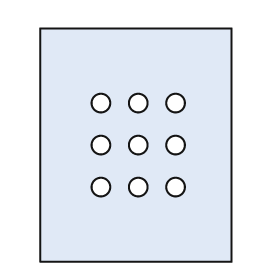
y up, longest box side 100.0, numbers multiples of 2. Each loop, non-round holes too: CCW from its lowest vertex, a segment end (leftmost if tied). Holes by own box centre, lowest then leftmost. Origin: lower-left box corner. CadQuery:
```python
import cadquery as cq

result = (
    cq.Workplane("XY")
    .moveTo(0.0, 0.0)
    .lineTo(82.0, 0.0)
    .lineTo(82.0, 100.0)
    .lineTo(0.0, 100.0)
    .close()
    .moveTo(26.0, 32.0)
    .circle(4.0)
    .moveTo(42.0, 32.0)
    .circle(4.0)
    .moveTo(58.0, 32.0)
    .circle(4.0)
    .moveTo(26.0, 50.0)
    .circle(4.0)
    .moveTo(42.0, 50.0)
    .circle(4.0)
    .moveTo(58.0, 50.0)
    .circle(4.0)
    .moveTo(26.0, 68.0)
    .circle(4.0)
    .moveTo(42.0, 68.0)
    .circle(4.0)
    .moveTo(58.0, 68.0)
    .circle(4.0)
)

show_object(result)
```